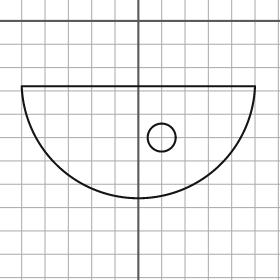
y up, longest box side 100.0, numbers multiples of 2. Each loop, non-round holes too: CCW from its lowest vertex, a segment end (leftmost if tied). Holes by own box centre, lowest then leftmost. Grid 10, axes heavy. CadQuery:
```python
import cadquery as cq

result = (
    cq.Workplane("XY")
    .moveTo(-50.0, -28.0)
    .threePointArc((0.0, -76.0), (50.0, -28.0))
    .close()
    .moveTo(10.0, -50.0)
    .circle(6.0)
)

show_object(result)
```